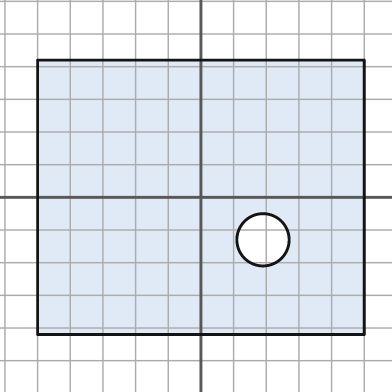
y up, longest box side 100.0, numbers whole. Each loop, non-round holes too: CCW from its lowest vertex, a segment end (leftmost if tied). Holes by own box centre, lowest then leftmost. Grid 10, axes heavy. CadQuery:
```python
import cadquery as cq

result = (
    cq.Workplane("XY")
    .moveTo(-50.0, -42.0)
    .lineTo(50.0, -42.0)
    .lineTo(50.0, 42.0)
    .lineTo(-50.0, 42.0)
    .close()
    .moveTo(19.0, -13.0)
    .circle(8.0)
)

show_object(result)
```